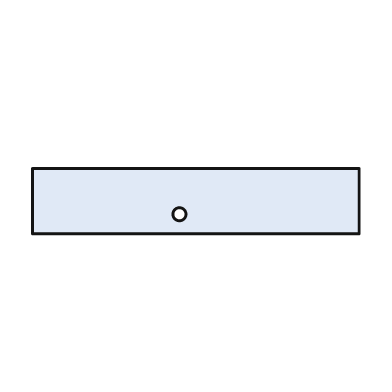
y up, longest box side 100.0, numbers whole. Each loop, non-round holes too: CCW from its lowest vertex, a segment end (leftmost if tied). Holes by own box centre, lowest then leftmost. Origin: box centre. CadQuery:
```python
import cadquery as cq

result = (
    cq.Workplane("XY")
    .moveTo(-50.0, -10.0)
    .lineTo(50.0, -10.0)
    .lineTo(50.0, 10.0)
    .lineTo(-50.0, 10.0)
    .close()
    .moveTo(-5.0, -4.0)
    .circle(2.0)
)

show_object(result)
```